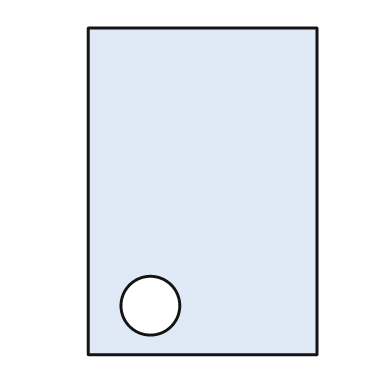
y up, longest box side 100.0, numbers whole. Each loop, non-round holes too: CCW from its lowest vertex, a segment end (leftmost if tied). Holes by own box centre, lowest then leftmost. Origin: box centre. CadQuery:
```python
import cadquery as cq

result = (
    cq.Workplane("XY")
    .moveTo(-35.0, -50.0)
    .lineTo(35.0, -50.0)
    .lineTo(35.0, 50.0)
    .lineTo(-35.0, 50.0)
    .close()
    .moveTo(-16.0, -35.0)
    .circle(9.0)
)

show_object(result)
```